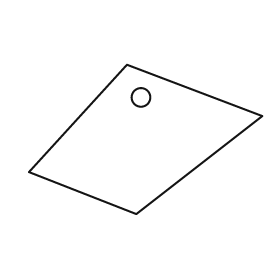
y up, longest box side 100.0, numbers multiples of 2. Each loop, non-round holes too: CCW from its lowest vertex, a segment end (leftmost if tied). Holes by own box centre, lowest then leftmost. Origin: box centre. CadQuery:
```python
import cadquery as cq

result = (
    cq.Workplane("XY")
    .moveTo(-4.0, -32.0)
    .lineTo(50.0, 10.0)
    .lineTo(-8.0, 32.0)
    .lineTo(-50.0, -14.0)
    .close()
    .moveTo(-2.0, 18.0)
    .circle(4.0)
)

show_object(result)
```